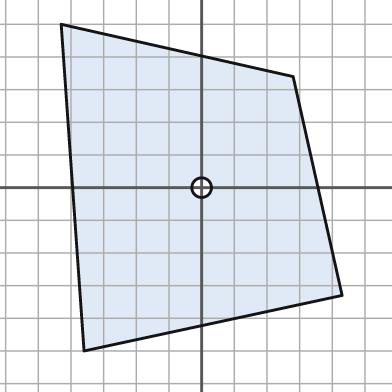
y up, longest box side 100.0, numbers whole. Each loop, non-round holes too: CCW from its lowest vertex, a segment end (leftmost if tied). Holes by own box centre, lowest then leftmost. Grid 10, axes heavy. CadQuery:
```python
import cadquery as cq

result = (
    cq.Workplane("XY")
    .moveTo(-36.0, -50.0)
    .lineTo(43.0, -33.0)
    .lineTo(28.0, 34.0)
    .lineTo(-43.0, 50.0)
    .close()
    .moveTo(0.0, 0.0)
    .circle(3.0)
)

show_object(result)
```